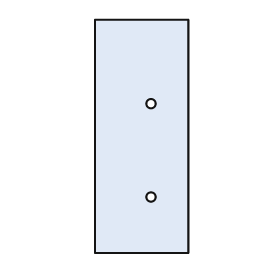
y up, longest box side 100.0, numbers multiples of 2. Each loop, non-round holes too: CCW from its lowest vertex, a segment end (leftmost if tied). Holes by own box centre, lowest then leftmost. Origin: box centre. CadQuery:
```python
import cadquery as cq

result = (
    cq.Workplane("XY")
    .moveTo(-20.0, -50.0)
    .lineTo(20.0, -50.0)
    .lineTo(20.0, 50.0)
    .lineTo(-20.0, 50.0)
    .close()
    .moveTo(4.0, -26.0)
    .circle(2.0)
    .moveTo(4.0, 14.0)
    .circle(2.0)
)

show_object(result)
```